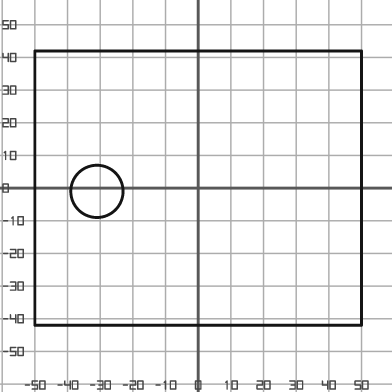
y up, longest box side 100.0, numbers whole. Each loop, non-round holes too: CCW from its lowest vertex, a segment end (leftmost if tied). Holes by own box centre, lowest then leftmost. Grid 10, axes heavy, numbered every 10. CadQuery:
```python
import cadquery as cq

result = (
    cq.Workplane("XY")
    .moveTo(-50.0, -42.0)
    .lineTo(50.0, -42.0)
    .lineTo(50.0, 42.0)
    .lineTo(-50.0, 42.0)
    .close()
    .moveTo(-31.0, -1.0)
    .circle(8.0)
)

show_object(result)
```